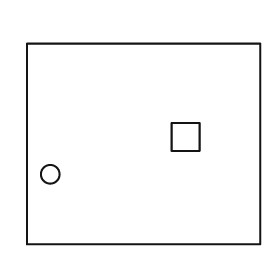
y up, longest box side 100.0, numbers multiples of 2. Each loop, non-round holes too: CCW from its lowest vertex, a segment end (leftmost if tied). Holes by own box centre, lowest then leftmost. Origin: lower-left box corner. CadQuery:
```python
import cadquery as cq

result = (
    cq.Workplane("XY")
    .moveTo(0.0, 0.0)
    .lineTo(100.0, 0.0)
    .lineTo(100.0, 86.0)
    .lineTo(0.0, 86.0)
    .close()
    .moveTo(10.0, 30.0)
    .circle(4.0)
    .moveTo(62.0, 40.0)
    .lineTo(74.0, 40.0)
    .lineTo(74.0, 52.0)
    .lineTo(62.0, 52.0)
    .close()
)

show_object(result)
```